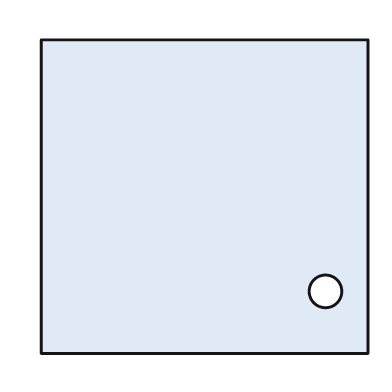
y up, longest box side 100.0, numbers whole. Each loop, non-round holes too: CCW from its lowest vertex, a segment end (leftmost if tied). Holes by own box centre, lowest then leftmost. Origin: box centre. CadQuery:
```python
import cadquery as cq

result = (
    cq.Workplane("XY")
    .moveTo(-50.0, -48.0)
    .lineTo(50.0, -48.0)
    .lineTo(50.0, 48.0)
    .lineTo(-50.0, 48.0)
    .close()
    .moveTo(37.0, -29.0)
    .circle(5.0)
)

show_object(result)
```